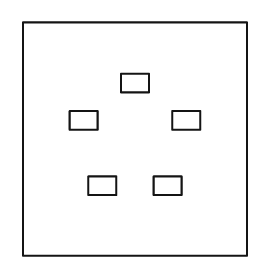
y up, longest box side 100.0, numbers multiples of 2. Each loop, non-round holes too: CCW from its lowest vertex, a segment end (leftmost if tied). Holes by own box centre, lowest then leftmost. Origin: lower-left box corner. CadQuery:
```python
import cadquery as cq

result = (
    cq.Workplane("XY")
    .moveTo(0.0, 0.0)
    .lineTo(96.0, 0.0)
    .lineTo(96.0, 100.0)
    .lineTo(0.0, 100.0)
    .close()
    .moveTo(28.0, 26.0)
    .lineTo(40.0, 26.0)
    .lineTo(40.0, 34.0)
    .lineTo(28.0, 34.0)
    .close()
    .moveTo(56.0, 26.0)
    .lineTo(68.0, 26.0)
    .lineTo(68.0, 34.0)
    .lineTo(56.0, 34.0)
    .close()
    .moveTo(20.0, 54.0)
    .lineTo(32.0, 54.0)
    .lineTo(32.0, 62.0)
    .lineTo(20.0, 62.0)
    .close()
    .moveTo(64.0, 54.0)
    .lineTo(76.0, 54.0)
    .lineTo(76.0, 62.0)
    .lineTo(64.0, 62.0)
    .close()
    .moveTo(42.0, 70.0)
    .lineTo(54.0, 70.0)
    .lineTo(54.0, 78.0)
    .lineTo(42.0, 78.0)
    .close()
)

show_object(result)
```